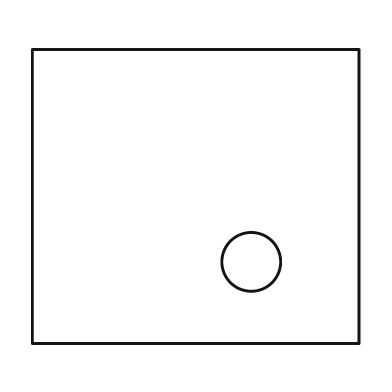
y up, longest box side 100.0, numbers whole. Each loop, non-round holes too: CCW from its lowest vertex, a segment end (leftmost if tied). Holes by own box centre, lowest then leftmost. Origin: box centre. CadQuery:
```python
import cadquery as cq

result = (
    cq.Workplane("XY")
    .moveTo(-50.0, -45.0)
    .lineTo(50.0, -45.0)
    .lineTo(50.0, 45.0)
    .lineTo(-50.0, 45.0)
    .close()
    .moveTo(17.0, -20.0)
    .circle(9.0)
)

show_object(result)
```